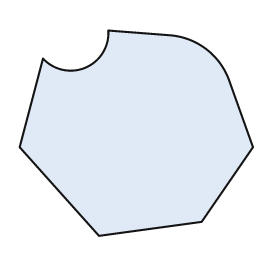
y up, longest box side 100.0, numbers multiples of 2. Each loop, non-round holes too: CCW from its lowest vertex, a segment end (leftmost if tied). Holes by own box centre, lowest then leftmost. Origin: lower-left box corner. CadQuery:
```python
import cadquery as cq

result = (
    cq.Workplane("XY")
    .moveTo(34.0, 0.0)
    .lineTo(78.0, 6.0)
    .lineTo(100.0, 38.0)
    .lineTo(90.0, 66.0)
    .threePointArc((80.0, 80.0), (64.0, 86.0))
    .lineTo(38.0, 88.0)
    .threePointArc((28.0, 72.0), (10.0, 76.0))
    .lineTo(0.0, 38.0)
    .close()
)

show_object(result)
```